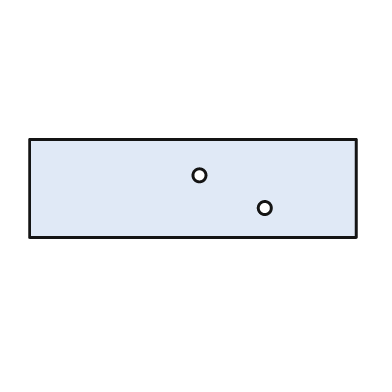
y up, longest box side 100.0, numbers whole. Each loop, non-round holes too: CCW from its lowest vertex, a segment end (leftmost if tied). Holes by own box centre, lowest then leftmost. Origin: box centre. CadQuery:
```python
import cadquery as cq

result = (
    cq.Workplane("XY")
    .moveTo(-50.0, -15.0)
    .lineTo(50.0, -15.0)
    .lineTo(50.0, 15.0)
    .lineTo(-50.0, 15.0)
    .close()
    .moveTo(22.0, -6.0)
    .circle(2.0)
    .moveTo(2.0, 4.0)
    .circle(2.0)
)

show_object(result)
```